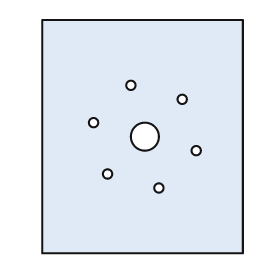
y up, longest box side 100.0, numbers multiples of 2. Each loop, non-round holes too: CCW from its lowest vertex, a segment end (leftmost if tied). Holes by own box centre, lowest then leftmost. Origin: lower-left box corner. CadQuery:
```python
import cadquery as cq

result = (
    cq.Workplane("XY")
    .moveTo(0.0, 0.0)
    .lineTo(86.0, 0.0)
    .lineTo(86.0, 100.0)
    .lineTo(0.0, 100.0)
    .close()
    .moveTo(50.0, 28.0)
    .circle(2.0)
    .moveTo(28.0, 34.0)
    .circle(2.0)
    .moveTo(66.0, 44.0)
    .circle(2.0)
    .moveTo(44.0, 50.0)
    .circle(6.0)
    .moveTo(22.0, 56.0)
    .circle(2.0)
    .moveTo(60.0, 66.0)
    .circle(2.0)
    .moveTo(38.0, 72.0)
    .circle(2.0)
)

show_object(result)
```